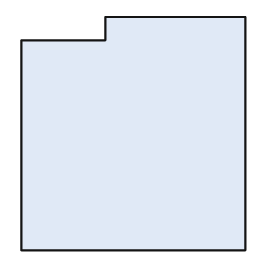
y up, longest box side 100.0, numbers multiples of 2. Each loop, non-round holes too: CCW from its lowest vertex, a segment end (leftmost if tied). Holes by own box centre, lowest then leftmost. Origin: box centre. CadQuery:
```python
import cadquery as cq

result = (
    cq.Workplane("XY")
    .moveTo(-48.0, -50.0)
    .lineTo(48.0, -50.0)
    .lineTo(48.0, 50.0)
    .lineTo(-12.0, 50.0)
    .lineTo(-12.0, 40.0)
    .lineTo(-48.0, 40.0)
    .close()
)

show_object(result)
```